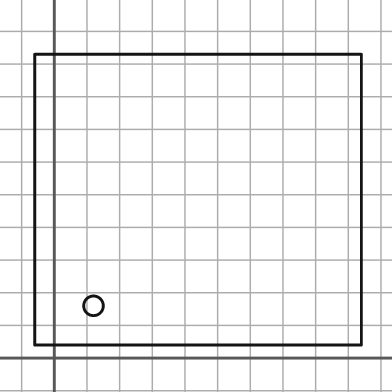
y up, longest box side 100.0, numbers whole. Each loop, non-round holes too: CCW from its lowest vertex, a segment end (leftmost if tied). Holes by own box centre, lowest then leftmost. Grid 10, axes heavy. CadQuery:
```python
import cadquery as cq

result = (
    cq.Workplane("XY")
    .moveTo(-6.0, 4.0)
    .lineTo(94.0, 4.0)
    .lineTo(94.0, 93.0)
    .lineTo(-6.0, 93.0)
    .close()
    .moveTo(12.0, 16.0)
    .circle(3.0)
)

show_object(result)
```